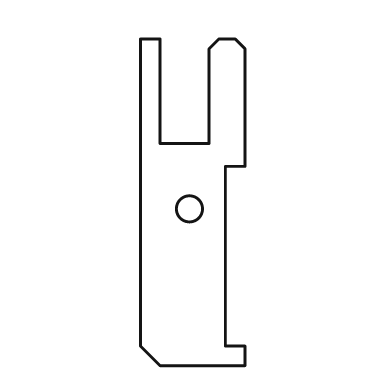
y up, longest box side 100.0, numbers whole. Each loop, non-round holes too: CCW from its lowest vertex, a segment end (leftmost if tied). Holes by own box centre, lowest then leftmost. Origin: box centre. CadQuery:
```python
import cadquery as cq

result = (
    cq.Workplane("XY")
    .moveTo(-10.0, -50.0)
    .lineTo(16.0, -50.0)
    .lineTo(16.0, -44.0)
    .lineTo(10.0, -44.0)
    .lineTo(10.0, 11.0)
    .lineTo(16.0, 11.0)
    .lineTo(16.0, 47.0)
    .lineTo(13.0, 50.0)
    .lineTo(8.0, 50.0)
    .lineTo(5.0, 47.0)
    .lineTo(5.0, 18.0)
    .lineTo(-10.0, 18.0)
    .lineTo(-10.0, 50.0)
    .lineTo(-16.0, 50.0)
    .lineTo(-16.0, -44.0)
    .close()
    .moveTo(-1.0, -2.0)
    .circle(4.0)
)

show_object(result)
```